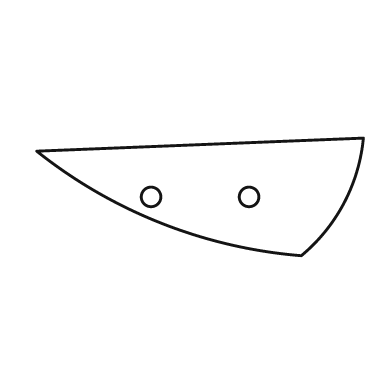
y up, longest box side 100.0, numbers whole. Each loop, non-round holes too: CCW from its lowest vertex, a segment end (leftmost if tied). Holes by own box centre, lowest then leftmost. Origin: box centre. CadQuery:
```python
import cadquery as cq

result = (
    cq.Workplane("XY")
    .moveTo(31.0, -18.0)
    .threePointArc((44.0, -2.0), (50.0, 18.0))
    .lineTo(-50.0, 14.0)
    .threePointArc((-12.0, -8.0), (31.0, -18.0))
    .close()
    .moveTo(-15.0, 0.0)
    .circle(3.0)
    .moveTo(15.0, 0.0)
    .circle(3.0)
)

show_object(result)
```